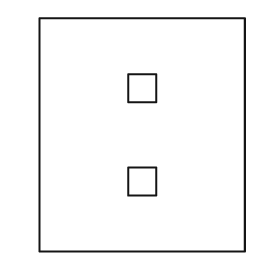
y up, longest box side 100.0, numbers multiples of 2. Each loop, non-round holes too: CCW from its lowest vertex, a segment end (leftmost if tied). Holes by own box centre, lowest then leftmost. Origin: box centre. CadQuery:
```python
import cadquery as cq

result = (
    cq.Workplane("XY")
    .moveTo(-44.0, -50.0)
    .lineTo(44.0, -50.0)
    .lineTo(44.0, 50.0)
    .lineTo(-44.0, 50.0)
    .close()
    .moveTo(-6.0, -26.0)
    .lineTo(6.0, -26.0)
    .lineTo(6.0, -14.0)
    .lineTo(-6.0, -14.0)
    .close()
    .moveTo(-6.0, 14.0)
    .lineTo(6.0, 14.0)
    .lineTo(6.0, 26.0)
    .lineTo(-6.0, 26.0)
    .close()
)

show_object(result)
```